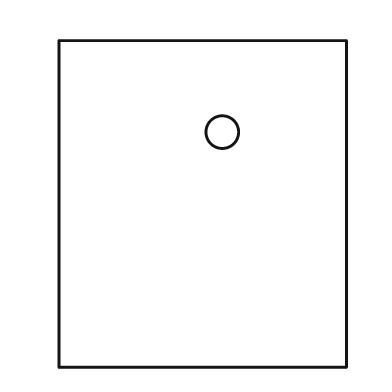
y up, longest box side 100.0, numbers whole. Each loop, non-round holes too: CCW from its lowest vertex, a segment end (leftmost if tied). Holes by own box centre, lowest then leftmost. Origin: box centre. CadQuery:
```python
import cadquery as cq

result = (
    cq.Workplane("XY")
    .moveTo(-44.0, -50.0)
    .lineTo(44.0, -50.0)
    .lineTo(44.0, 50.0)
    .lineTo(-44.0, 50.0)
    .close()
    .moveTo(6.0, 22.0)
    .circle(5.0)
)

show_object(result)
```